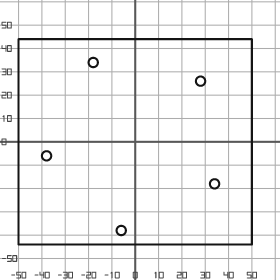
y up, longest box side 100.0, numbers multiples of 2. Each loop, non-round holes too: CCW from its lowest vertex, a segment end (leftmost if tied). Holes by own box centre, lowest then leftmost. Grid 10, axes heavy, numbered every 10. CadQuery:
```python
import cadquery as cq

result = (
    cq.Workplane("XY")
    .moveTo(-50.0, -44.0)
    .lineTo(50.0, -44.0)
    .lineTo(50.0, 44.0)
    .lineTo(-50.0, 44.0)
    .close()
    .moveTo(-6.0, -38.0)
    .circle(2.0)
    .moveTo(34.0, -18.0)
    .circle(2.0)
    .moveTo(-38.0, -6.0)
    .circle(2.0)
    .moveTo(28.0, 26.0)
    .circle(2.0)
    .moveTo(-18.0, 34.0)
    .circle(2.0)
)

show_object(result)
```